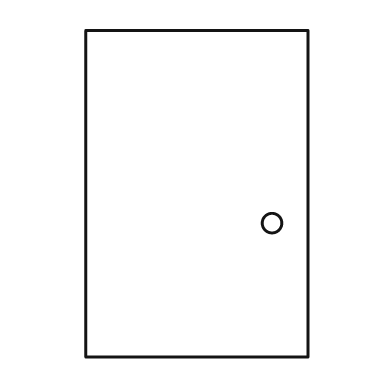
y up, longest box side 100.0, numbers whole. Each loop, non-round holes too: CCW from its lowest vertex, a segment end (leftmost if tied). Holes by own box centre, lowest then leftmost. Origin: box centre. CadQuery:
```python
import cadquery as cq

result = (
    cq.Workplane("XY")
    .moveTo(-34.0, -50.0)
    .lineTo(34.0, -50.0)
    .lineTo(34.0, 50.0)
    .lineTo(-34.0, 50.0)
    .close()
    .moveTo(23.0, -9.0)
    .circle(3.0)
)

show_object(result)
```